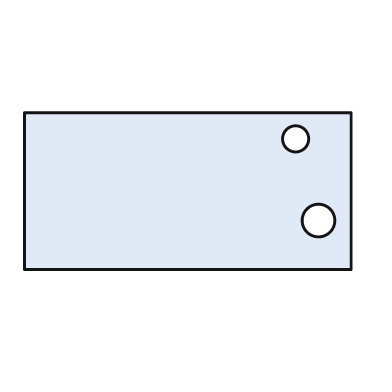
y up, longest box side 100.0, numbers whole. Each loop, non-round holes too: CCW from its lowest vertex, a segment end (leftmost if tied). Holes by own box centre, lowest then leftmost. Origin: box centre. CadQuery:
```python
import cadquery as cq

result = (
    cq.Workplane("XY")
    .moveTo(-50.0, -24.0)
    .lineTo(50.0, -24.0)
    .lineTo(50.0, 24.0)
    .lineTo(-50.0, 24.0)
    .close()
    .moveTo(40.0, -9.0)
    .circle(5.0)
    .moveTo(33.0, 16.0)
    .circle(4.0)
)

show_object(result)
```